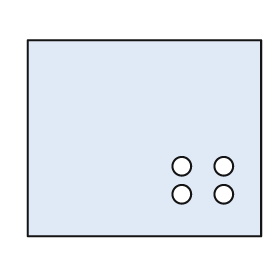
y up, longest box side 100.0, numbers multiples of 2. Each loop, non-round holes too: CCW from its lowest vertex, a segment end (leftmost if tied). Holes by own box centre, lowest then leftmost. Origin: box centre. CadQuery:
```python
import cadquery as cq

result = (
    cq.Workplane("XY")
    .moveTo(-50.0, -42.0)
    .lineTo(50.0, -42.0)
    .lineTo(50.0, 42.0)
    .lineTo(-50.0, 42.0)
    .close()
    .moveTo(16.0, -24.0)
    .circle(4.0)
    .moveTo(34.0, -24.0)
    .circle(4.0)
    .moveTo(16.0, -12.0)
    .circle(4.0)
    .moveTo(34.0, -12.0)
    .circle(4.0)
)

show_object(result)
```